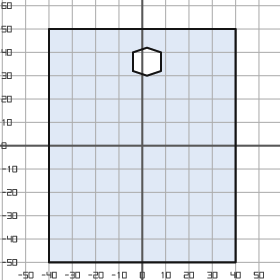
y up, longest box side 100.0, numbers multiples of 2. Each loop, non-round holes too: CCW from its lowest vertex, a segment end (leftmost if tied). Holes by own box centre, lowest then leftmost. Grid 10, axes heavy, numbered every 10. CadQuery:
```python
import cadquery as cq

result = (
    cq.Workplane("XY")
    .moveTo(-40.0, -50.0)
    .lineTo(40.0, -50.0)
    .lineTo(40.0, 50.0)
    .lineTo(-40.0, 50.0)
    .close()
    .moveTo(2.0, 30.0)
    .lineTo(8.0, 32.0)
    .lineTo(8.0, 40.0)
    .lineTo(2.0, 42.0)
    .lineTo(-4.0, 40.0)
    .lineTo(-4.0, 32.0)
    .close()
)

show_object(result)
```